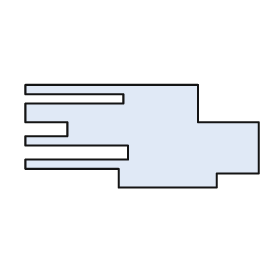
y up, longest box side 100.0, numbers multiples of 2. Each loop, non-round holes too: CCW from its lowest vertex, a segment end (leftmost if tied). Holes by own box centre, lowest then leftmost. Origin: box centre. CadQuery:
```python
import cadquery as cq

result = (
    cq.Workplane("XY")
    .moveTo(-10.0, -22.0)
    .lineTo(32.0, -22.0)
    .lineTo(32.0, -16.0)
    .lineTo(50.0, -16.0)
    .lineTo(50.0, 6.0)
    .lineTo(24.0, 6.0)
    .lineTo(24.0, 22.0)
    .lineTo(-50.0, 22.0)
    .lineTo(-50.0, 18.0)
    .lineTo(-8.0, 18.0)
    .lineTo(-8.0, 14.0)
    .lineTo(-50.0, 14.0)
    .lineTo(-50.0, 6.0)
    .lineTo(-32.0, 6.0)
    .lineTo(-32.0, 0.0)
    .lineTo(-50.0, 0.0)
    .lineTo(-50.0, -4.0)
    .lineTo(-6.0, -4.0)
    .lineTo(-6.0, -10.0)
    .lineTo(-50.0, -10.0)
    .lineTo(-50.0, -14.0)
    .lineTo(-10.0, -14.0)
    .close()
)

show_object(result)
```